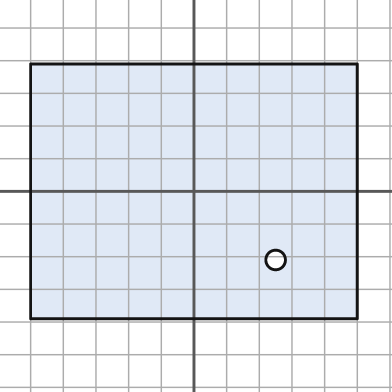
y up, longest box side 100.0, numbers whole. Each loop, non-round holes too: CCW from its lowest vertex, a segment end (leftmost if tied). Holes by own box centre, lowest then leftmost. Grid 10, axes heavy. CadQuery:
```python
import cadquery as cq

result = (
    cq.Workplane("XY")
    .moveTo(-50.0, -39.0)
    .lineTo(50.0, -39.0)
    .lineTo(50.0, 39.0)
    .lineTo(-50.0, 39.0)
    .close()
    .moveTo(25.0, -21.0)
    .circle(3.0)
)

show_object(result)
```